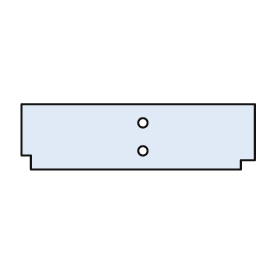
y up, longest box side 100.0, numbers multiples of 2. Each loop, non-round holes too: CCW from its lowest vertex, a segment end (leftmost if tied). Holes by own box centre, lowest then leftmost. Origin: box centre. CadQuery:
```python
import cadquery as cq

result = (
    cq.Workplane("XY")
    .moveTo(-46.0, -14.0)
    .lineTo(44.0, -14.0)
    .lineTo(44.0, -10.0)
    .lineTo(50.0, -10.0)
    .lineTo(50.0, 14.0)
    .lineTo(-50.0, 14.0)
    .lineTo(-50.0, -8.0)
    .lineTo(-46.0, -8.0)
    .close()
    .moveTo(2.0, -6.0)
    .circle(2.0)
    .moveTo(2.0, 6.0)
    .circle(2.0)
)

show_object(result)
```